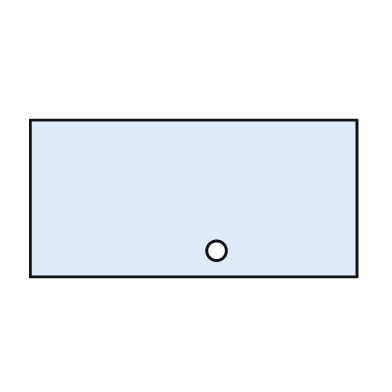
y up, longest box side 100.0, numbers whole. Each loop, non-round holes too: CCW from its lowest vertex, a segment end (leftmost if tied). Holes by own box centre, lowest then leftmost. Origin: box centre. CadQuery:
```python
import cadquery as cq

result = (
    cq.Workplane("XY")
    .moveTo(-50.0, -24.0)
    .lineTo(50.0, -24.0)
    .lineTo(50.0, 24.0)
    .lineTo(-50.0, 24.0)
    .close()
    .moveTo(7.0, -16.0)
    .circle(3.0)
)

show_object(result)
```